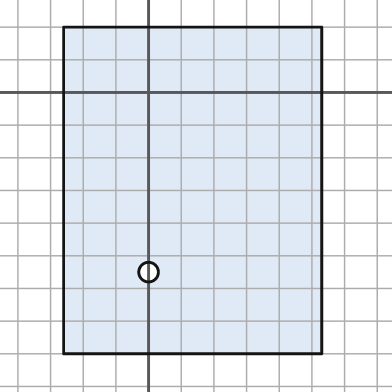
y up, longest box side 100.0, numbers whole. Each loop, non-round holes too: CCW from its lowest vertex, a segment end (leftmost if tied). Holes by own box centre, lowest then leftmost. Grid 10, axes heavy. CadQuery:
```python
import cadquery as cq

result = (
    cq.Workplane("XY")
    .moveTo(-26.0, -80.0)
    .lineTo(53.0, -80.0)
    .lineTo(53.0, 20.0)
    .lineTo(-26.0, 20.0)
    .close()
    .moveTo(0.0, -55.0)
    .circle(3.0)
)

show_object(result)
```